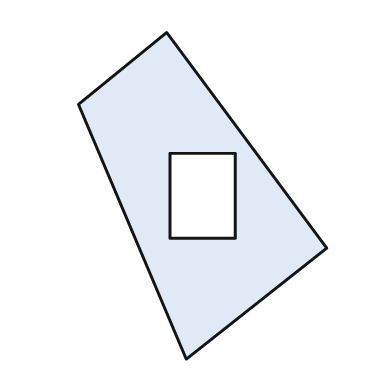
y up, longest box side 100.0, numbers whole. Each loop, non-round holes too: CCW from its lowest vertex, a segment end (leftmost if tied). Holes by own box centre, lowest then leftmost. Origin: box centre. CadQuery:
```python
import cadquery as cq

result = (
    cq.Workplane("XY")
    .moveTo(-5.0, -50.0)
    .lineTo(38.0, -16.0)
    .lineTo(-11.0, 50.0)
    .lineTo(-38.0, 28.0)
    .close()
    .moveTo(-10.0, -13.0)
    .lineTo(10.0, -13.0)
    .lineTo(10.0, 13.0)
    .lineTo(-10.0, 13.0)
    .close()
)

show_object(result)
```